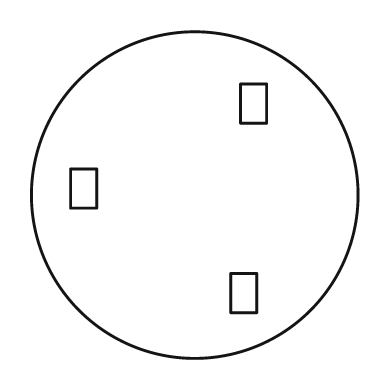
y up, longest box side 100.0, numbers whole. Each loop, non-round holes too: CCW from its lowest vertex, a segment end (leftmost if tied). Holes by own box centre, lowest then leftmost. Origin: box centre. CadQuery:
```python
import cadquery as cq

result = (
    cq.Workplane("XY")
    .moveTo(0.0, 0.0)
    .circle(50.0)
    .moveTo(11.0, -36.0)
    .lineTo(19.0, -36.0)
    .lineTo(19.0, -24.0)
    .lineTo(11.0, -24.0)
    .close()
    .moveTo(-38.0, -4.0)
    .lineTo(-30.0, -4.0)
    .lineTo(-30.0, 8.0)
    .lineTo(-38.0, 8.0)
    .close()
    .moveTo(14.0, 22.0)
    .lineTo(22.0, 22.0)
    .lineTo(22.0, 34.0)
    .lineTo(14.0, 34.0)
    .close()
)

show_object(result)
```